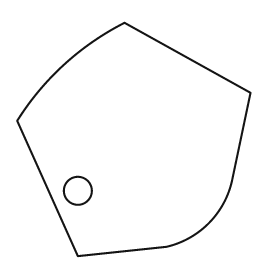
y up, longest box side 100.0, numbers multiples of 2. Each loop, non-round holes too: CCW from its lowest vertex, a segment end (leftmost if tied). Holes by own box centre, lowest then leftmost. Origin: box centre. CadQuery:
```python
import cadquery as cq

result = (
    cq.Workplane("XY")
    .moveTo(-24.0, -50.0)
    .lineTo(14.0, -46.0)
    .threePointArc((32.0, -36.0), (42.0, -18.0))
    .lineTo(50.0, 20.0)
    .lineTo(-4.0, 50.0)
    .threePointArc((-30.0, 32.0), (-50.0, 8.0))
    .close()
    .moveTo(-24.0, -22.0)
    .circle(6.0)
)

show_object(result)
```